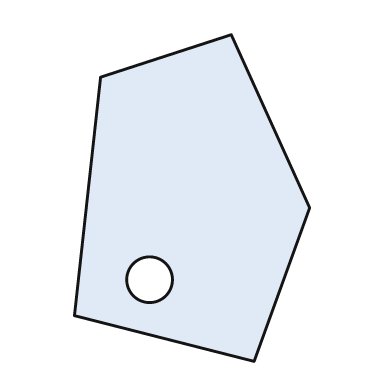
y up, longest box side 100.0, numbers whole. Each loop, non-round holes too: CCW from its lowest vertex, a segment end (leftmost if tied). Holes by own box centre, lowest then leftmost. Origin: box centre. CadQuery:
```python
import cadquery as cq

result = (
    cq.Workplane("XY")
    .moveTo(19.0, -50.0)
    .lineTo(36.0, -3.0)
    .lineTo(12.0, 50.0)
    .lineTo(-28.0, 37.0)
    .lineTo(-36.0, -36.0)
    .close()
    .moveTo(-13.0, -25.0)
    .circle(7.0)
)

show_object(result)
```